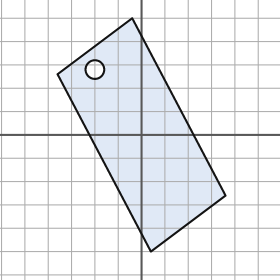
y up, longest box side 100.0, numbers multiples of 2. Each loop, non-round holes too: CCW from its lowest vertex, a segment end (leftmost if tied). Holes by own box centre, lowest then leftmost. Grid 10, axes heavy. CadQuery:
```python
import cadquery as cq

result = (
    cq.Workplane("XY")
    .moveTo(4.0, -50.0)
    .lineTo(36.0, -26.0)
    .lineTo(-4.0, 50.0)
    .lineTo(-36.0, 26.0)
    .close()
    .moveTo(-20.0, 28.0)
    .circle(4.0)
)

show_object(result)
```